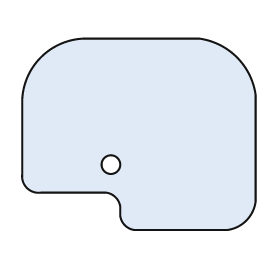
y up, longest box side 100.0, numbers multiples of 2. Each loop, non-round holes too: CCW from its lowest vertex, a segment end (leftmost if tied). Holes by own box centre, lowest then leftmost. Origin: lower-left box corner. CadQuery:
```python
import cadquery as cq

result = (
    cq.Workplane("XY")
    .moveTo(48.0, 0.0)
    .lineTo(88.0, 0.0)
    .threePointArc((96.0, 4.0), (100.0, 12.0))
    .lineTo(100.0, 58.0)
    .threePointArc((92.0, 74.0), (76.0, 82.0))
    .lineTo(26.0, 82.0)
    .threePointArc((8.0, 74.0), (0.0, 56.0))
    .lineTo(0.0, 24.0)
    .threePointArc((2.0, 18.0), (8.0, 16.0))
    .lineTo(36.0, 16.0)
    .threePointArc((40.0, 14.0), (42.0, 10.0))
    .lineTo(42.0, 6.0)
    .threePointArc((44.0, 2.0), (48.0, 0.0))
    .close()
    .moveTo(38.0, 28.0)
    .circle(4.0)
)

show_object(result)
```